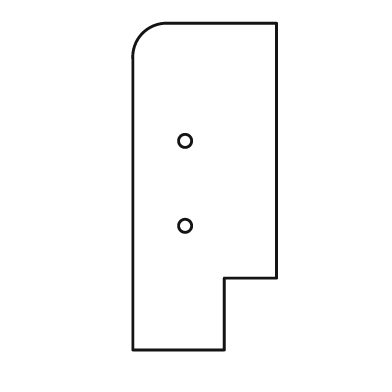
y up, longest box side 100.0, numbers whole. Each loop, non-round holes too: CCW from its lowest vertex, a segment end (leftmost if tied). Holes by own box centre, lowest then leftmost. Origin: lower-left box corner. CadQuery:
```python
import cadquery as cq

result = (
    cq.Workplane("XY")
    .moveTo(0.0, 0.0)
    .lineTo(28.0, 0.0)
    .lineTo(28.0, 22.0)
    .lineTo(44.0, 22.0)
    .lineTo(44.0, 100.0)
    .lineTo(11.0, 100.0)
    .threePointArc((3.0, 97.0), (0.0, 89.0))
    .close()
    .moveTo(16.0, 38.0)
    .circle(2.0)
    .moveTo(16.0, 64.0)
    .circle(2.0)
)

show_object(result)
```